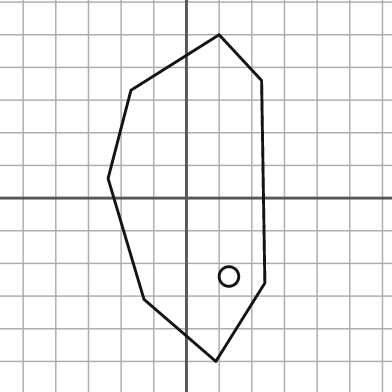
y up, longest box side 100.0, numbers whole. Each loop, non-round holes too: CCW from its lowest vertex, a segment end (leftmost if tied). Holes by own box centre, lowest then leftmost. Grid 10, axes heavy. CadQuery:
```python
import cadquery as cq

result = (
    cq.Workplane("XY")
    .moveTo(9.0, -50.0)
    .lineTo(24.0, -26.0)
    .lineTo(23.0, 36.0)
    .lineTo(10.0, 50.0)
    .lineTo(-17.0, 33.0)
    .lineTo(-24.0, 6.0)
    .lineTo(-13.0, -31.0)
    .close()
    .moveTo(13.0, -24.0)
    .circle(3.0)
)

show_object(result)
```